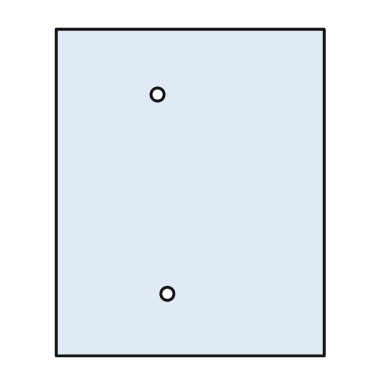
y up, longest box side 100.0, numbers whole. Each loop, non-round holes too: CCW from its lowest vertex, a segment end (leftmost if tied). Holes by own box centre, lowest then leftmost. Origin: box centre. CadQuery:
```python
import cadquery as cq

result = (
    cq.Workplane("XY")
    .moveTo(-41.0, -50.0)
    .lineTo(41.0, -50.0)
    .lineTo(41.0, 50.0)
    .lineTo(-41.0, 50.0)
    .close()
    .moveTo(-7.0, -31.0)
    .circle(2.0)
    .moveTo(-10.0, 30.0)
    .circle(2.0)
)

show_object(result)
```